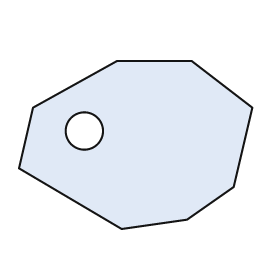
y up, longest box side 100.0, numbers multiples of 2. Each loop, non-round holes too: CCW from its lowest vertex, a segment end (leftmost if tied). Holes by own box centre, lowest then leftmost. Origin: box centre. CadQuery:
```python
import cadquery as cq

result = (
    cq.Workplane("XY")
    .moveTo(-6.0, -36.0)
    .lineTo(22.0, -32.0)
    .lineTo(42.0, -18.0)
    .lineTo(50.0, 16.0)
    .lineTo(24.0, 36.0)
    .lineTo(-8.0, 36.0)
    .lineTo(-44.0, 16.0)
    .lineTo(-50.0, -10.0)
    .close()
    .moveTo(-22.0, 6.0)
    .circle(8.0)
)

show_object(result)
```